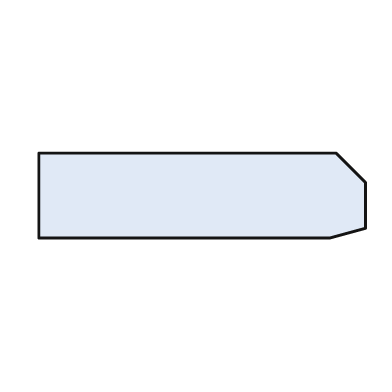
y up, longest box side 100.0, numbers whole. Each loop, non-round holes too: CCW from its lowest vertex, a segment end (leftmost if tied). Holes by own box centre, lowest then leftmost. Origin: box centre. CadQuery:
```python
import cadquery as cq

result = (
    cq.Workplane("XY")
    .moveTo(-50.0, -13.0)
    .lineTo(39.0, -13.0)
    .lineTo(50.0, -10.0)
    .lineTo(50.0, 4.0)
    .lineTo(41.0, 13.0)
    .lineTo(-50.0, 13.0)
    .close()
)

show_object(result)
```